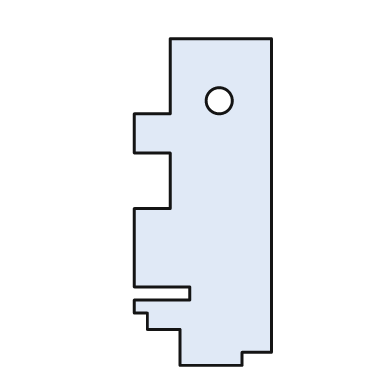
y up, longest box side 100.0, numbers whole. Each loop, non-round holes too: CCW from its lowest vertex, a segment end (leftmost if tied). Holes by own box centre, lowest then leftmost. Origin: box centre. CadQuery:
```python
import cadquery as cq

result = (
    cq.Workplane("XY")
    .moveTo(-7.0, -50.0)
    .lineTo(12.0, -50.0)
    .lineTo(12.0, -46.0)
    .lineTo(21.0, -46.0)
    .lineTo(21.0, 50.0)
    .lineTo(-10.0, 50.0)
    .lineTo(-10.0, 27.0)
    .lineTo(-21.0, 27.0)
    .lineTo(-21.0, 15.0)
    .lineTo(-10.0, 15.0)
    .lineTo(-10.0, -2.0)
    .lineTo(-21.0, -2.0)
    .lineTo(-21.0, -26.0)
    .lineTo(-4.0, -26.0)
    .lineTo(-4.0, -30.0)
    .lineTo(-21.0, -30.0)
    .lineTo(-21.0, -34.0)
    .lineTo(-17.0, -34.0)
    .lineTo(-17.0, -39.0)
    .lineTo(-7.0, -39.0)
    .close()
    .moveTo(5.0, 31.0)
    .circle(4.0)
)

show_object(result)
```